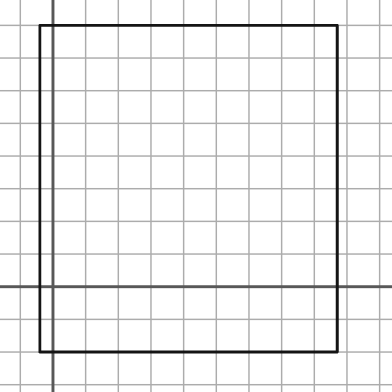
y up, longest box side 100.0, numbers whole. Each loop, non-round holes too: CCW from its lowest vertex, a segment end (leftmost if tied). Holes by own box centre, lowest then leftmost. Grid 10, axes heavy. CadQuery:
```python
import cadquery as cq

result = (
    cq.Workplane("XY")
    .moveTo(-4.0, -20.0)
    .lineTo(87.0, -20.0)
    .lineTo(87.0, 80.0)
    .lineTo(-4.0, 80.0)
    .close()
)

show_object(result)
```